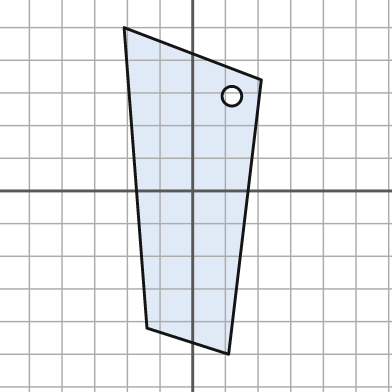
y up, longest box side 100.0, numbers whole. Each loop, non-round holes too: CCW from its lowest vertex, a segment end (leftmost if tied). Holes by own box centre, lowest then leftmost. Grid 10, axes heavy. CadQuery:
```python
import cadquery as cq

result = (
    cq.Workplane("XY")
    .moveTo(11.0, -50.0)
    .lineTo(21.0, 34.0)
    .lineTo(-21.0, 50.0)
    .lineTo(-14.0, -42.0)
    .close()
    .moveTo(12.0, 29.0)
    .circle(3.0)
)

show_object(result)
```